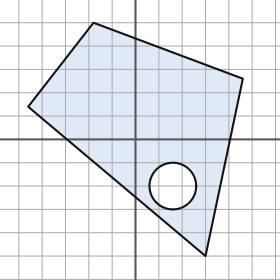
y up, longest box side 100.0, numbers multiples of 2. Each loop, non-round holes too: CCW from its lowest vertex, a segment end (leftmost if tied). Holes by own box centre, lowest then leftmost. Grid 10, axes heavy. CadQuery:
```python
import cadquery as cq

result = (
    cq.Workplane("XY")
    .moveTo(30.0, -50.0)
    .lineTo(46.0, 26.0)
    .lineTo(-18.0, 50.0)
    .lineTo(-46.0, 14.0)
    .close()
    .moveTo(16.0, -20.0)
    .circle(10.0)
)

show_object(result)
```